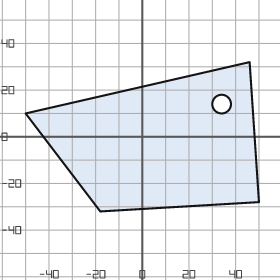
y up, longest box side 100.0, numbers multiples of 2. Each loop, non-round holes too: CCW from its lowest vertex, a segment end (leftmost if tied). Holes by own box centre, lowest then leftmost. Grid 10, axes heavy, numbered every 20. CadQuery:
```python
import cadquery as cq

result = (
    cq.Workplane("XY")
    .moveTo(-18.0, -32.0)
    .lineTo(50.0, -28.0)
    .lineTo(46.0, 32.0)
    .lineTo(-50.0, 10.0)
    .close()
    .moveTo(34.0, 14.0)
    .circle(4.0)
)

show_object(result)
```